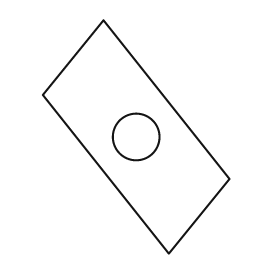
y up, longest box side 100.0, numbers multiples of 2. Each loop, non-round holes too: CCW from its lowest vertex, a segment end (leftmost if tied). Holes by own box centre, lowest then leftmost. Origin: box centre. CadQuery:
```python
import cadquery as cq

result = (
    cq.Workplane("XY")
    .moveTo(14.0, -50.0)
    .lineTo(40.0, -18.0)
    .lineTo(-14.0, 50.0)
    .lineTo(-40.0, 18.0)
    .close()
    .moveTo(0.0, 0.0)
    .circle(10.0)
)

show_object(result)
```